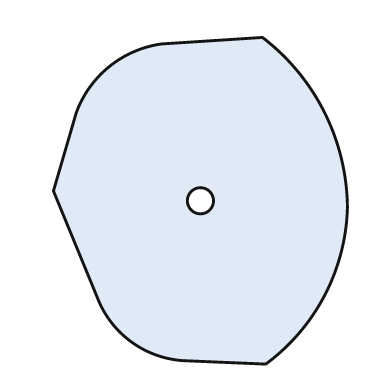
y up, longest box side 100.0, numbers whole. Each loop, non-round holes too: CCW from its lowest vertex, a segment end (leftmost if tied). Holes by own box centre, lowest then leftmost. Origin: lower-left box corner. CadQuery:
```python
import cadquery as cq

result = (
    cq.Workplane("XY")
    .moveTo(65.0, 0.0)
    .threePointArc((83.0, 21.0), (90.0, 48.0))
    .threePointArc((83.0, 77.0), (64.0, 100.0))
    .lineTo(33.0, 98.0)
    .threePointArc((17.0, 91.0), (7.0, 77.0))
    .lineTo(0.0, 53.0)
    .lineTo(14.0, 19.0)
    .threePointArc((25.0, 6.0), (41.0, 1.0))
    .close()
    .moveTo(45.0, 50.0)
    .circle(4.0)
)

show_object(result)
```